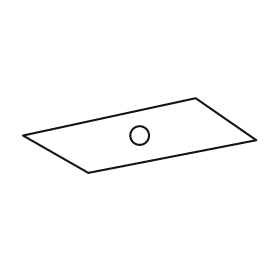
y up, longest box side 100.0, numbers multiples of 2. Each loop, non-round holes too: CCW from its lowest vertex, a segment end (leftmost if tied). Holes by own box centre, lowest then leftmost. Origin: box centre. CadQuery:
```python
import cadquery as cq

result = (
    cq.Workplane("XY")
    .moveTo(-22.0, -16.0)
    .lineTo(50.0, -2.0)
    .lineTo(24.0, 16.0)
    .lineTo(-50.0, 0.0)
    .close()
    .moveTo(0.0, 0.0)
    .circle(4.0)
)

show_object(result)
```